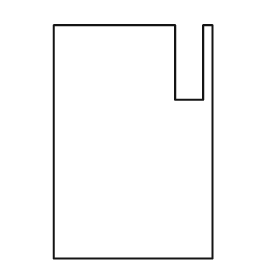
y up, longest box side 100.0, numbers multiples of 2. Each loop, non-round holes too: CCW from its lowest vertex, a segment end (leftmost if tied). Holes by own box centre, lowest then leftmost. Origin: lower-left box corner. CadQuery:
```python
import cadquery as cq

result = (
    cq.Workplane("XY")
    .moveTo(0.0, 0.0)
    .lineTo(68.0, 0.0)
    .lineTo(68.0, 100.0)
    .lineTo(64.0, 100.0)
    .lineTo(64.0, 68.0)
    .lineTo(52.0, 68.0)
    .lineTo(52.0, 100.0)
    .lineTo(0.0, 100.0)
    .close()
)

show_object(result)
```